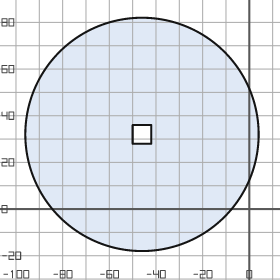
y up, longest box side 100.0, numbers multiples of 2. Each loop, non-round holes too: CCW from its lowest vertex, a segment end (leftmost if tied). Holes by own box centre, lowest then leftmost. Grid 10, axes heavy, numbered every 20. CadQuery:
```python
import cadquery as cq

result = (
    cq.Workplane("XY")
    .moveTo(-46.0, 32.0)
    .circle(50.0)
    .moveTo(-50.0, 28.0)
    .lineTo(-42.0, 28.0)
    .lineTo(-42.0, 36.0)
    .lineTo(-50.0, 36.0)
    .close()
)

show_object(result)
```